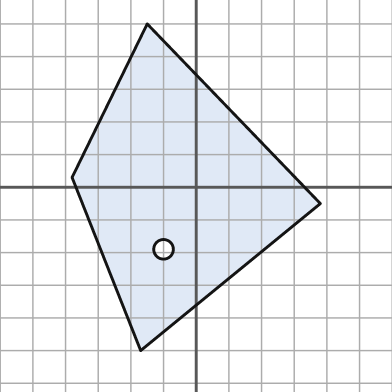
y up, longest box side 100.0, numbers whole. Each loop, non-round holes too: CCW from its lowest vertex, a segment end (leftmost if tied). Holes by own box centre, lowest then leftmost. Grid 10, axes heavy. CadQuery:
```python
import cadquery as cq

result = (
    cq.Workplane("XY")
    .moveTo(-17.0, -50.0)
    .lineTo(38.0, -5.0)
    .lineTo(-15.0, 50.0)
    .lineTo(-38.0, 3.0)
    .close()
    .moveTo(-10.0, -19.0)
    .circle(3.0)
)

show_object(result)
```